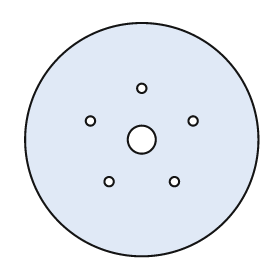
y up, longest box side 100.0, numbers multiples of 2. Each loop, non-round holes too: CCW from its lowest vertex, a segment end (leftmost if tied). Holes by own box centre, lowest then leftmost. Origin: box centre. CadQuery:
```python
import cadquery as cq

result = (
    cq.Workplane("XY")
    .moveTo(0.0, 0.0)
    .circle(50.0)
    .moveTo(-14.0, -18.0)
    .circle(2.0)
    .moveTo(14.0, -18.0)
    .circle(2.0)
    .moveTo(0.0, 0.0)
    .circle(6.0)
    .moveTo(-22.0, 8.0)
    .circle(2.0)
    .moveTo(22.0, 8.0)
    .circle(2.0)
    .moveTo(0.0, 22.0)
    .circle(2.0)
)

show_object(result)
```